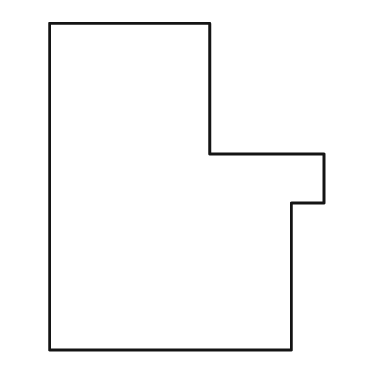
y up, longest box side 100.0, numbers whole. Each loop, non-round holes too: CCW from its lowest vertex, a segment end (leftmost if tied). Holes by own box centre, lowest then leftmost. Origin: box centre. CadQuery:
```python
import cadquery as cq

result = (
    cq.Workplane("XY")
    .moveTo(-42.0, -50.0)
    .lineTo(32.0, -50.0)
    .lineTo(32.0, -5.0)
    .lineTo(42.0, -5.0)
    .lineTo(42.0, 10.0)
    .lineTo(7.0, 10.0)
    .lineTo(7.0, 50.0)
    .lineTo(-42.0, 50.0)
    .close()
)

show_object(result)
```